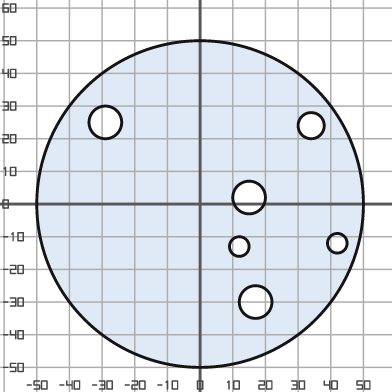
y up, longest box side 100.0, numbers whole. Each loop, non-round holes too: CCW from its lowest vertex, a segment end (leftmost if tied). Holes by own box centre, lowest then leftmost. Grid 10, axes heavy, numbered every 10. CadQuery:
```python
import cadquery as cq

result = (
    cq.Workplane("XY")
    .moveTo(0.0, 0.0)
    .circle(50.0)
    .moveTo(17.0, -30.0)
    .circle(5.0)
    .moveTo(12.0, -13.0)
    .circle(3.0)
    .moveTo(42.0, -12.0)
    .circle(3.0)
    .moveTo(15.0, 2.0)
    .circle(5.0)
    .moveTo(34.0, 24.0)
    .circle(4.0)
    .moveTo(-29.0, 25.0)
    .circle(5.0)
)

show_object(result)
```